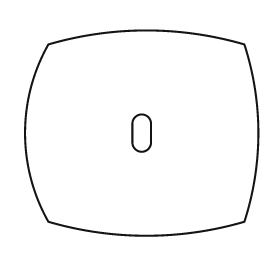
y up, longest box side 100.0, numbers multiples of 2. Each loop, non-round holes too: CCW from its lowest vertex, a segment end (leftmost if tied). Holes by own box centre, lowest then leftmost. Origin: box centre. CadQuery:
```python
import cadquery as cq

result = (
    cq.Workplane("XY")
    .moveTo(-40.0, -38.0)
    .threePointArc((2.0, -44.0), (44.0, -38.0))
    .threePointArc((50.0, 0.0), (44.0, 38.0))
    .threePointArc((2.0, 44.0), (-40.0, 38.0))
    .threePointArc((-50.0, 0.0), (-40.0, -38.0))
    .close()
    .moveTo(-4.0, -4.0)
    .threePointArc((0.0, -8.0), (4.0, -4.0))
    .lineTo(4.0, 4.0)
    .threePointArc((0.0, 8.0), (-4.0, 4.0))
    .close()
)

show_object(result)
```